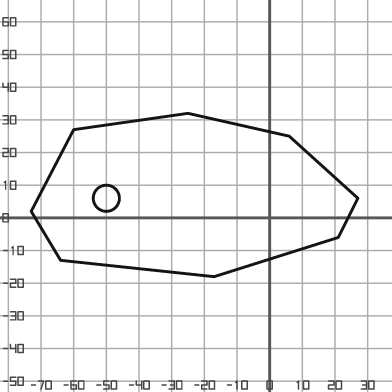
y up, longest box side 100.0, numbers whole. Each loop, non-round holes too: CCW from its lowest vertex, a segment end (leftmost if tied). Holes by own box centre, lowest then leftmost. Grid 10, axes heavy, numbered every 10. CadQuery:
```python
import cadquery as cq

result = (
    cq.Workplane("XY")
    .moveTo(-17.0, -18.0)
    .lineTo(21.0, -6.0)
    .lineTo(27.0, 6.0)
    .lineTo(6.0, 25.0)
    .lineTo(-25.0, 32.0)
    .lineTo(-60.0, 27.0)
    .lineTo(-73.0, 2.0)
    .lineTo(-64.0, -13.0)
    .close()
    .moveTo(-50.0, 6.0)
    .circle(4.0)
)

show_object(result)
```